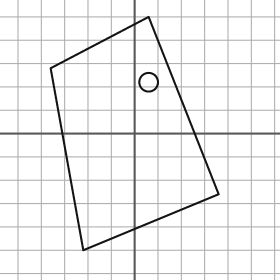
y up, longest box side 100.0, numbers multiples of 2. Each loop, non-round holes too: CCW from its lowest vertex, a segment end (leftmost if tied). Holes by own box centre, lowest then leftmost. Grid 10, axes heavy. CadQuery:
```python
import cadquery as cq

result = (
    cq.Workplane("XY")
    .moveTo(-22.0, -50.0)
    .lineTo(36.0, -26.0)
    .lineTo(6.0, 50.0)
    .lineTo(-36.0, 28.0)
    .close()
    .moveTo(6.0, 22.0)
    .circle(4.0)
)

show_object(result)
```